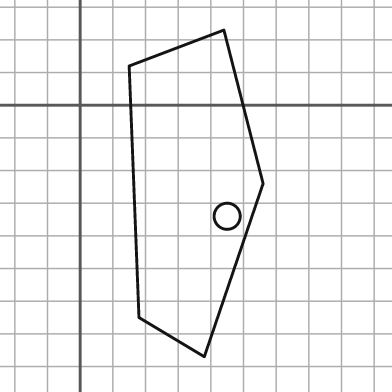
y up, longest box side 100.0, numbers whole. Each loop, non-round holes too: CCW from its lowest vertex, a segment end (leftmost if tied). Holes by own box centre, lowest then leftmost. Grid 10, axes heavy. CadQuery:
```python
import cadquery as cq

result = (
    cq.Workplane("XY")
    .moveTo(38.0, -77.0)
    .lineTo(56.0, -24.0)
    .lineTo(44.0, 23.0)
    .lineTo(15.0, 12.0)
    .lineTo(18.0, -65.0)
    .close()
    .moveTo(45.0, -34.0)
    .circle(4.0)
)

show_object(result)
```